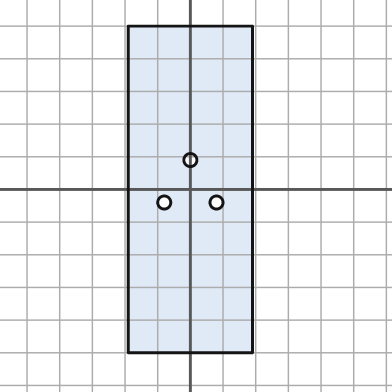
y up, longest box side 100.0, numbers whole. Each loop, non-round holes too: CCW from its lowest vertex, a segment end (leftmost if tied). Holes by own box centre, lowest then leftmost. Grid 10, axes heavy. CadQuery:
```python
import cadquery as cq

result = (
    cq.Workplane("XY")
    .moveTo(-19.0, -50.0)
    .lineTo(19.0, -50.0)
    .lineTo(19.0, 50.0)
    .lineTo(-19.0, 50.0)
    .close()
    .moveTo(-8.0, -4.0)
    .circle(2.0)
    .moveTo(8.0, -4.0)
    .circle(2.0)
    .moveTo(0.0, 9.0)
    .circle(2.0)
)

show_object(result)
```